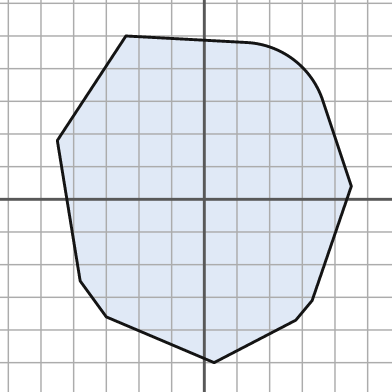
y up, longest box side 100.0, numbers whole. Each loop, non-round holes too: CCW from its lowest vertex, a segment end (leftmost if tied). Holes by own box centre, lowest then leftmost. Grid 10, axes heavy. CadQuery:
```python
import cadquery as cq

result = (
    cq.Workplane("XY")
    .moveTo(3.0, -50.0)
    .lineTo(28.0, -37.0)
    .lineTo(33.0, -31.0)
    .lineTo(45.0, 4.0)
    .lineTo(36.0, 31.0)
    .threePointArc((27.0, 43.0), (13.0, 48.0))
    .lineTo(-24.0, 50.0)
    .lineTo(-45.0, 18.0)
    .lineTo(-38.0, -25.0)
    .lineTo(-30.0, -36.0)
    .close()
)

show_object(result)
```